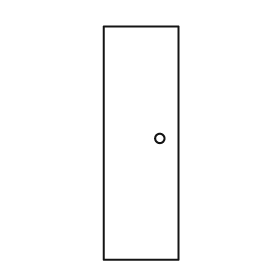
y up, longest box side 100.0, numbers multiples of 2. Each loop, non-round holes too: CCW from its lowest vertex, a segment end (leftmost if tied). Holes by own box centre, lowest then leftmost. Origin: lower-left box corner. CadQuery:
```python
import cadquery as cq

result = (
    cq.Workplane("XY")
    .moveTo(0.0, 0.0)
    .lineTo(32.0, 0.0)
    .lineTo(32.0, 100.0)
    .lineTo(0.0, 100.0)
    .close()
    .moveTo(24.0, 52.0)
    .circle(2.0)
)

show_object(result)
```